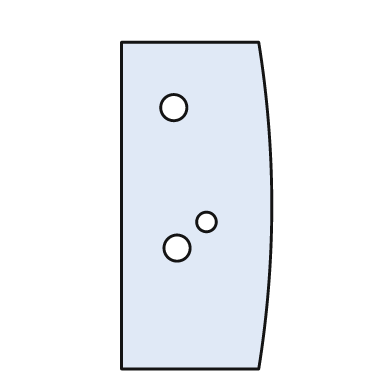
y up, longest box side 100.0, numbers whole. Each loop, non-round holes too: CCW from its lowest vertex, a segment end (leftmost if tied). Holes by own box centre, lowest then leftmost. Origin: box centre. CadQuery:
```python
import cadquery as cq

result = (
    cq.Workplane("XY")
    .moveTo(-23.0, -50.0)
    .lineTo(19.0, -50.0)
    .threePointArc((23.0, 0.0), (19.0, 50.0))
    .lineTo(-23.0, 50.0)
    .close()
    .moveTo(-6.0, -13.0)
    .circle(4.0)
    .moveTo(3.0, -5.0)
    .circle(3.0)
    .moveTo(-7.0, 30.0)
    .circle(4.0)
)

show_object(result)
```